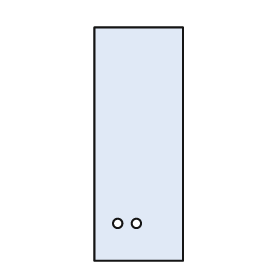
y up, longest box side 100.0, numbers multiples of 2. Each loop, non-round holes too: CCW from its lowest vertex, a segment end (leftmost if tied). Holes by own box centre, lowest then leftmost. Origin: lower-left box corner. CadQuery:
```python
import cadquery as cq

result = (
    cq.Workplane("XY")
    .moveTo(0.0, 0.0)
    .lineTo(38.0, 0.0)
    .lineTo(38.0, 100.0)
    .lineTo(0.0, 100.0)
    .close()
    .moveTo(10.0, 16.0)
    .circle(2.0)
    .moveTo(18.0, 16.0)
    .circle(2.0)
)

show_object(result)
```